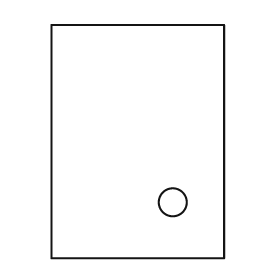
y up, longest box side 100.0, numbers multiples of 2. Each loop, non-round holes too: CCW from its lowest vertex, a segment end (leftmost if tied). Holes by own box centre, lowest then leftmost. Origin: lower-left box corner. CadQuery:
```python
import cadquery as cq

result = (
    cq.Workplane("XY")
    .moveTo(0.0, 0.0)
    .lineTo(74.0, 0.0)
    .lineTo(74.0, 100.0)
    .lineTo(0.0, 100.0)
    .close()
    .moveTo(52.0, 24.0)
    .circle(6.0)
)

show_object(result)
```